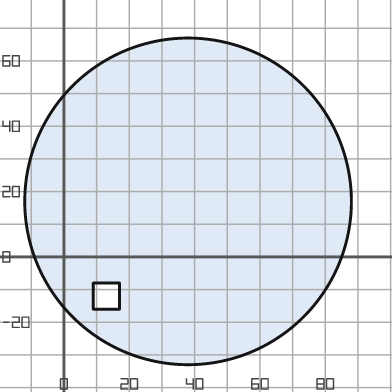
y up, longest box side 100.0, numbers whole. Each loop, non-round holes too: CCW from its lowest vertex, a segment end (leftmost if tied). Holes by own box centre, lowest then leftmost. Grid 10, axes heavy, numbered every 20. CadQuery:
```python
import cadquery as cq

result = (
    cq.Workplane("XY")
    .moveTo(38.0, 17.0)
    .circle(50.0)
    .moveTo(9.0, -16.0)
    .lineTo(17.0, -16.0)
    .lineTo(17.0, -8.0)
    .lineTo(9.0, -8.0)
    .close()
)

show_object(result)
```